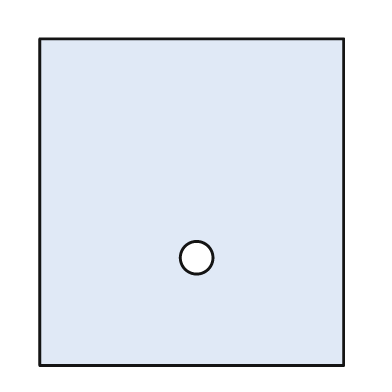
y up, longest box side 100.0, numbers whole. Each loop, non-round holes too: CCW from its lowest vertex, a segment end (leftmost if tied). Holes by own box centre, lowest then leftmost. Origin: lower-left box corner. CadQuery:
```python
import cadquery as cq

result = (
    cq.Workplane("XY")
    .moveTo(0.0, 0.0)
    .lineTo(93.0, 0.0)
    .lineTo(93.0, 100.0)
    .lineTo(0.0, 100.0)
    .close()
    .moveTo(48.0, 33.0)
    .circle(5.0)
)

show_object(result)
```